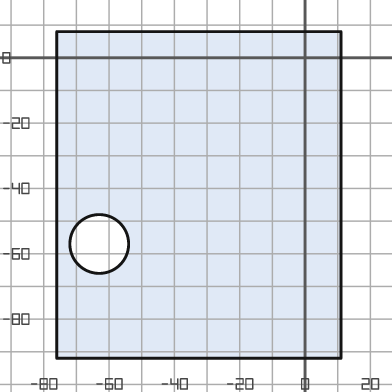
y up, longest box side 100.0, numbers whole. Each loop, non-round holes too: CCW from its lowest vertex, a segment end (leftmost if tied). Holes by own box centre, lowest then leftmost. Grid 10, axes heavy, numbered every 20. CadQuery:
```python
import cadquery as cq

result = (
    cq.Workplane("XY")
    .moveTo(-76.0, -92.0)
    .lineTo(11.0, -92.0)
    .lineTo(11.0, 8.0)
    .lineTo(-76.0, 8.0)
    .close()
    .moveTo(-63.0, -57.0)
    .circle(9.0)
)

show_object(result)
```